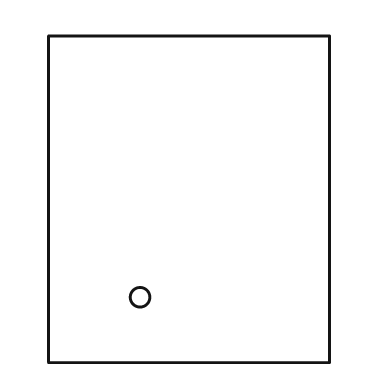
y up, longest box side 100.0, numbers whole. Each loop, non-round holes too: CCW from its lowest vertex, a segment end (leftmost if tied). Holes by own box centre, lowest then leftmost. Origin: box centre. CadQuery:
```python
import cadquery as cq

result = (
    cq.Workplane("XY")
    .moveTo(-43.0, -50.0)
    .lineTo(43.0, -50.0)
    .lineTo(43.0, 50.0)
    .lineTo(-43.0, 50.0)
    .close()
    .moveTo(-15.0, -30.0)
    .circle(3.0)
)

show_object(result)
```